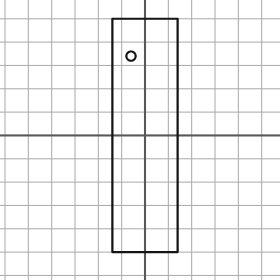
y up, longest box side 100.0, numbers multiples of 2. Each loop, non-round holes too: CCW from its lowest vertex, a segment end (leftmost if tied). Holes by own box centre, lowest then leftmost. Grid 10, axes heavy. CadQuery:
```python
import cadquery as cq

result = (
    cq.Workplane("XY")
    .moveTo(-14.0, -50.0)
    .lineTo(14.0, -50.0)
    .lineTo(14.0, 50.0)
    .lineTo(-14.0, 50.0)
    .close()
    .moveTo(-6.0, 34.0)
    .circle(2.0)
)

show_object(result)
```